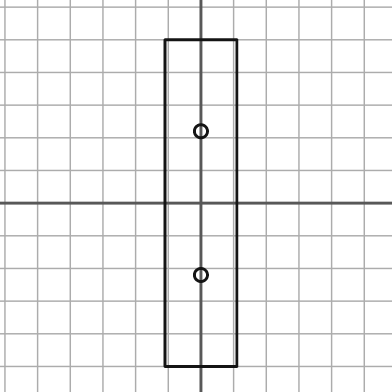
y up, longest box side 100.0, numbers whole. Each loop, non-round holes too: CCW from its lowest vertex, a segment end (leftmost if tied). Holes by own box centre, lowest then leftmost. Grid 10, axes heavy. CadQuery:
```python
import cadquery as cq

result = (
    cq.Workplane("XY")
    .moveTo(-11.0, -50.0)
    .lineTo(11.0, -50.0)
    .lineTo(11.0, 50.0)
    .lineTo(-11.0, 50.0)
    .close()
    .moveTo(0.0, -22.0)
    .circle(2.0)
    .moveTo(0.0, 22.0)
    .circle(2.0)
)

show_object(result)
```